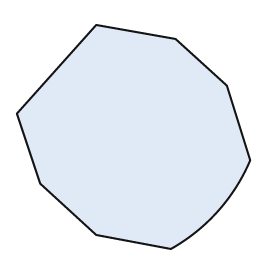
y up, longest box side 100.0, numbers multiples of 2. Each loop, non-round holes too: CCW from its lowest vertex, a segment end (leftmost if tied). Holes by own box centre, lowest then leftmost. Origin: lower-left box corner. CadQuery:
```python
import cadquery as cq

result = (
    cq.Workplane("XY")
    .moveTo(66.0, 0.0)
    .threePointArc((86.0, 16.0), (100.0, 38.0))
    .lineTo(90.0, 70.0)
    .lineTo(68.0, 90.0)
    .lineTo(34.0, 96.0)
    .lineTo(0.0, 58.0)
    .lineTo(10.0, 28.0)
    .lineTo(34.0, 6.0)
    .close()
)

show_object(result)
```